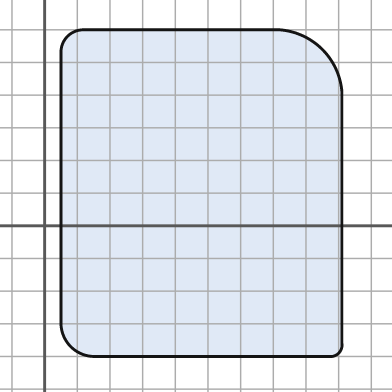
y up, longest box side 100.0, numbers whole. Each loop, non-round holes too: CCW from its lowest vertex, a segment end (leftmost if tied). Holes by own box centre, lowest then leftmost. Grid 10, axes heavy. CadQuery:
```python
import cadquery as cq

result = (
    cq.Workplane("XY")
    .moveTo(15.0, -40.0)
    .lineTo(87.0, -40.0)
    .threePointArc((90.0, -39.0), (91.0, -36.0))
    .lineTo(91.0, 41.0)
    .threePointArc((85.0, 54.0), (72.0, 60.0))
    .lineTo(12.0, 60.0)
    .threePointArc((7.0, 58.0), (5.0, 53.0))
    .lineTo(5.0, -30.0)
    .threePointArc((8.0, -37.0), (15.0, -40.0))
    .close()
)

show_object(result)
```